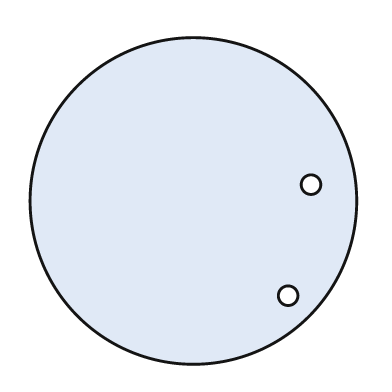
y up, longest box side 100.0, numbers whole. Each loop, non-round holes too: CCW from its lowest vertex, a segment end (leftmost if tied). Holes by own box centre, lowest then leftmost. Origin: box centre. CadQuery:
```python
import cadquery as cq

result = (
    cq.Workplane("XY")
    .moveTo(0.0, 0.0)
    .circle(50.0)
    .moveTo(29.0, -29.0)
    .circle(3.0)
    .moveTo(36.0, 5.0)
    .circle(3.0)
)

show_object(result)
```